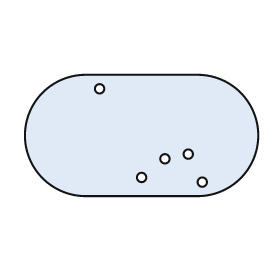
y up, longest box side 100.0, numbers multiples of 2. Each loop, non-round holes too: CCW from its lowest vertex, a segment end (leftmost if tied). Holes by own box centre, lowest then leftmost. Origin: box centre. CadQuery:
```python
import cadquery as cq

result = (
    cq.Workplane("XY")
    .moveTo(-24.0, -26.0)
    .lineTo(24.0, -26.0)
    .threePointArc((50.0, 0.0), (24.0, 26.0))
    .lineTo(-24.0, 26.0)
    .threePointArc((-50.0, 0.0), (-24.0, -26.0))
    .close()
    .moveTo(26.0, -20.0)
    .circle(2.0)
    .moveTo(0.0, -18.0)
    .circle(2.0)
    .moveTo(10.0, -10.0)
    .circle(2.0)
    .moveTo(20.0, -8.0)
    .circle(2.0)
    .moveTo(-18.0, 20.0)
    .circle(2.0)
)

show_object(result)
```